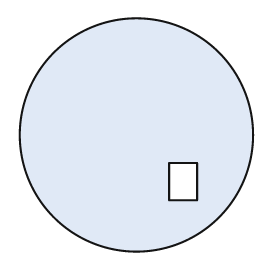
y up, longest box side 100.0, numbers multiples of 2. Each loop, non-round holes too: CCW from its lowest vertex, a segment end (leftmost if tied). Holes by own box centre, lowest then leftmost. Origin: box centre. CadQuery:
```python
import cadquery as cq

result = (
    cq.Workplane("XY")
    .moveTo(0.0, 0.0)
    .circle(50.0)
    .moveTo(14.0, -28.0)
    .lineTo(26.0, -28.0)
    .lineTo(26.0, -12.0)
    .lineTo(14.0, -12.0)
    .close()
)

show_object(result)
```